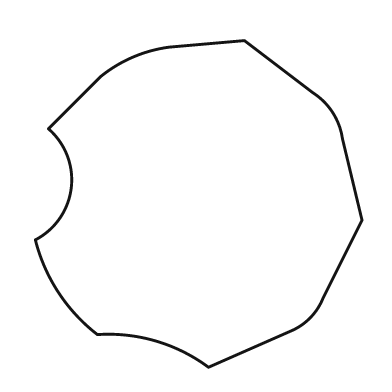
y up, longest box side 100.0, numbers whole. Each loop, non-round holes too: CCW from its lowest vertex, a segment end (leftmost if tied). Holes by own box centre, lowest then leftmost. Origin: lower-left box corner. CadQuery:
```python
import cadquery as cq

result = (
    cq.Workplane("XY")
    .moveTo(53.0, 0.0)
    .lineTo(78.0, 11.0)
    .threePointArc((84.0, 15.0), (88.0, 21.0))
    .lineTo(100.0, 45.0)
    .lineTo(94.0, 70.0)
    .threePointArc((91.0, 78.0), (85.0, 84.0))
    .lineTo(64.0, 100.0)
    .lineTo(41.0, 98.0)
    .threePointArc((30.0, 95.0), (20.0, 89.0))
    .lineTo(4.0, 73.0)
    .threePointArc((11.0, 55.0), (0.0, 39.0))
    .threePointArc((7.0, 23.0), (19.0, 10.0))
    .threePointArc((37.0, 8.0), (53.0, 0.0))
    .close()
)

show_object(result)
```